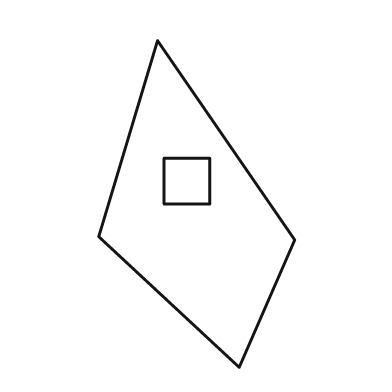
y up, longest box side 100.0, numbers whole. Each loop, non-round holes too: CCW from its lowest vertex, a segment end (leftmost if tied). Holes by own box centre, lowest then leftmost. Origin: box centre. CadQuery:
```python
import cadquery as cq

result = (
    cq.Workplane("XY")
    .moveTo(13.0, -50.0)
    .lineTo(30.0, -11.0)
    .lineTo(-12.0, 50.0)
    .lineTo(-30.0, -10.0)
    .close()
    .moveTo(-10.0, 0.0)
    .lineTo(4.0, 0.0)
    .lineTo(4.0, 14.0)
    .lineTo(-10.0, 14.0)
    .close()
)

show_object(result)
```